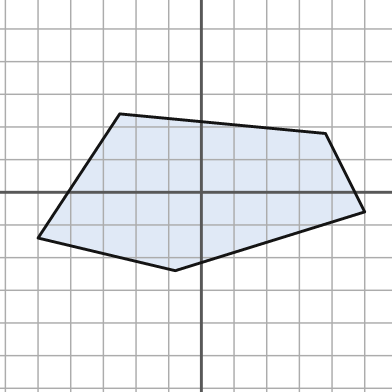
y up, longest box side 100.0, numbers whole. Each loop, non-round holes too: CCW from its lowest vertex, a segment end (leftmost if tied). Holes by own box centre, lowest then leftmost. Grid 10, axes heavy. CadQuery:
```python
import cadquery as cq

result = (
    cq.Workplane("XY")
    .moveTo(-8.0, -24.0)
    .lineTo(50.0, -6.0)
    .lineTo(38.0, 18.0)
    .lineTo(-25.0, 24.0)
    .lineTo(-50.0, -14.0)
    .close()
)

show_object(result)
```